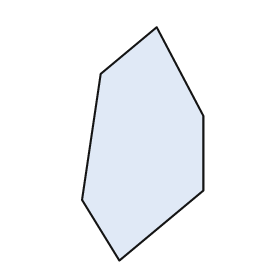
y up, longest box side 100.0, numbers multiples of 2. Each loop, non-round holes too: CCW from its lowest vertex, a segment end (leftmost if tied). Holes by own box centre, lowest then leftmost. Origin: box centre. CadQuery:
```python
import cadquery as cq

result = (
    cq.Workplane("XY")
    .moveTo(-10.0, -50.0)
    .lineTo(26.0, -20.0)
    .lineTo(26.0, 12.0)
    .lineTo(6.0, 50.0)
    .lineTo(-18.0, 30.0)
    .lineTo(-26.0, -24.0)
    .close()
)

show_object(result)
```